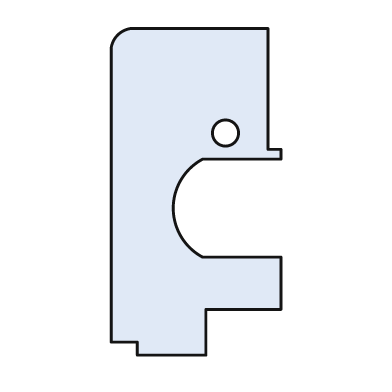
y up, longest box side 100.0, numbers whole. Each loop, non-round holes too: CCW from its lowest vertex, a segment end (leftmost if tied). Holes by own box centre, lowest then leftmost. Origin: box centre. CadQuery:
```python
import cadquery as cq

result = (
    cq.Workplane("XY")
    .moveTo(-18.0, -50.0)
    .lineTo(3.0, -50.0)
    .lineTo(3.0, -36.0)
    .lineTo(26.0, -36.0)
    .lineTo(26.0, -20.0)
    .lineTo(2.0, -20.0)
    .threePointArc((-7.0, -5.0), (2.0, 10.0))
    .lineTo(26.0, 10.0)
    .lineTo(26.0, 13.0)
    .lineTo(22.0, 13.0)
    .lineTo(22.0, 50.0)
    .lineTo(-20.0, 50.0)
    .threePointArc((-24.0, 48.0), (-26.0, 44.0))
    .lineTo(-26.0, -46.0)
    .lineTo(-18.0, -46.0)
    .close()
    .moveTo(9.0, 18.0)
    .circle(4.0)
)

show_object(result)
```